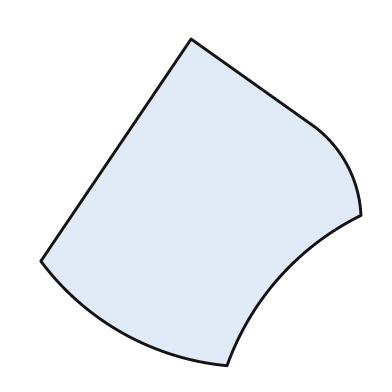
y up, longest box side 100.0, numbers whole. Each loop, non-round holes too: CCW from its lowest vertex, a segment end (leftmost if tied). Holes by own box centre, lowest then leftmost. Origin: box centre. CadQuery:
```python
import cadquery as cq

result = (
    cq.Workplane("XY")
    .moveTo(8.0, -50.0)
    .threePointArc((24.0, -23.0), (49.0, -4.0))
    .threePointArc((45.0, 11.0), (35.0, 23.0))
    .lineTo(-3.0, 50.0)
    .lineTo(-49.0, -18.0)
    .threePointArc((-24.0, -40.0), (8.0, -50.0))
    .close()
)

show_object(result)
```